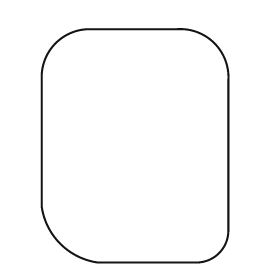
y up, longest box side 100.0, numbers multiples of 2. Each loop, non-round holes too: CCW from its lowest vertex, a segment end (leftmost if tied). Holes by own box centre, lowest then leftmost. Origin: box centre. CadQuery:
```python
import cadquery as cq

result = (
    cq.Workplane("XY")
    .moveTo(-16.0, -50.0)
    .lineTo(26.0, -50.0)
    .threePointArc((36.0, -46.0), (40.0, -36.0))
    .lineTo(40.0, 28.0)
    .threePointArc((34.0, 44.0), (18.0, 50.0))
    .lineTo(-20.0, 50.0)
    .threePointArc((-34.0, 44.0), (-40.0, 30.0))
    .lineTo(-40.0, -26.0)
    .threePointArc((-32.0, -42.0), (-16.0, -50.0))
    .close()
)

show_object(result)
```